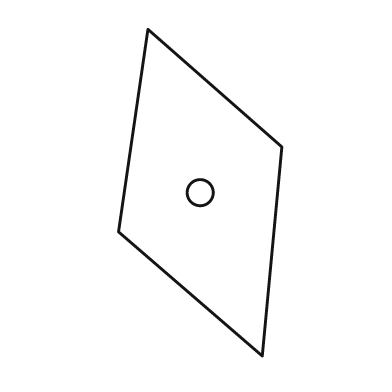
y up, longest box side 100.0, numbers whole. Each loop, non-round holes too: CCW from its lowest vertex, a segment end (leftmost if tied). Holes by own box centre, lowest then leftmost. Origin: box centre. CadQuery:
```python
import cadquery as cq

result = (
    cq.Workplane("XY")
    .moveTo(19.0, -50.0)
    .lineTo(25.0, 14.0)
    .lineTo(-16.0, 50.0)
    .lineTo(-25.0, -12.0)
    .close()
    .moveTo(0.0, 0.0)
    .circle(4.0)
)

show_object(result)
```